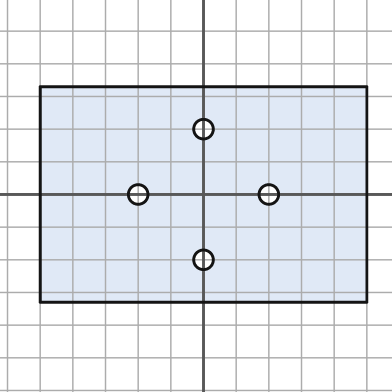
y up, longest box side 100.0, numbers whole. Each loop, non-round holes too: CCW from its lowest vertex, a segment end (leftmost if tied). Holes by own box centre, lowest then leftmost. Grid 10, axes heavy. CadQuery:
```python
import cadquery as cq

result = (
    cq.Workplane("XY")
    .moveTo(-50.0, -33.0)
    .lineTo(50.0, -33.0)
    .lineTo(50.0, 33.0)
    .lineTo(-50.0, 33.0)
    .close()
    .moveTo(0.0, -20.0)
    .circle(3.0)
    .moveTo(-20.0, 0.0)
    .circle(3.0)
    .moveTo(20.0, 0.0)
    .circle(3.0)
    .moveTo(0.0, 20.0)
    .circle(3.0)
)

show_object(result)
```